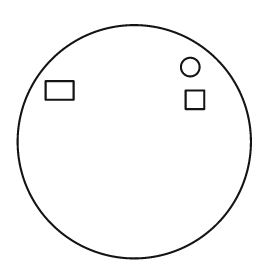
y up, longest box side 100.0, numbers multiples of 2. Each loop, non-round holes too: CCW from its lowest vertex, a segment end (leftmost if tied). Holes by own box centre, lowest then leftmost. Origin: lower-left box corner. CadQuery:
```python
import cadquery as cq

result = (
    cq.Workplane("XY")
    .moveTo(50.0, 50.0)
    .circle(50.0)
    .moveTo(72.0, 64.0)
    .lineTo(80.0, 64.0)
    .lineTo(80.0, 72.0)
    .lineTo(72.0, 72.0)
    .close()
    .moveTo(12.0, 68.0)
    .lineTo(24.0, 68.0)
    .lineTo(24.0, 76.0)
    .lineTo(12.0, 76.0)
    .close()
    .moveTo(74.0, 82.0)
    .circle(4.0)
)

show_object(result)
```